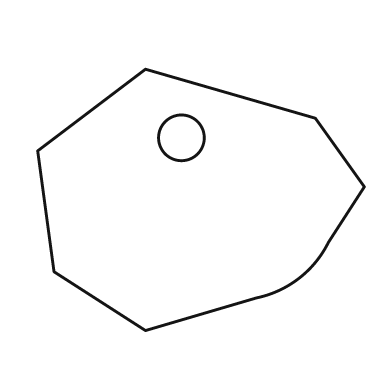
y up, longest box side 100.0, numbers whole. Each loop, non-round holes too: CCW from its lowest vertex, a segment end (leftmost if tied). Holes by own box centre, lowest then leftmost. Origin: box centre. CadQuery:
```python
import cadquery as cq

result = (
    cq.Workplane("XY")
    .moveTo(-17.0, -40.0)
    .lineTo(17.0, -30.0)
    .threePointArc((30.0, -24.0), (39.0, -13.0))
    .lineTo(50.0, 4.0)
    .lineTo(35.0, 25.0)
    .lineTo(-17.0, 40.0)
    .lineTo(-50.0, 15.0)
    .lineTo(-45.0, -22.0)
    .close()
    .moveTo(-6.0, 19.0)
    .circle(7.0)
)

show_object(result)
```